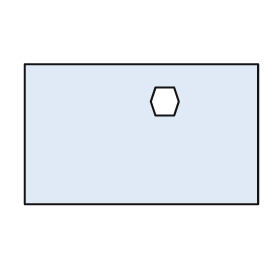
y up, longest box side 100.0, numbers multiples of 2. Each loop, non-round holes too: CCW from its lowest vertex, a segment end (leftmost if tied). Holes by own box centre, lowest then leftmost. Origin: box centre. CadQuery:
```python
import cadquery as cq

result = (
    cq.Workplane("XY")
    .moveTo(-50.0, -30.0)
    .lineTo(50.0, -30.0)
    .lineTo(50.0, 30.0)
    .lineTo(-50.0, 30.0)
    .close()
    .moveTo(6.0, 8.0)
    .lineTo(14.0, 8.0)
    .lineTo(16.0, 14.0)
    .lineTo(14.0, 20.0)
    .lineTo(6.0, 20.0)
    .lineTo(4.0, 14.0)
    .close()
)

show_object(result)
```